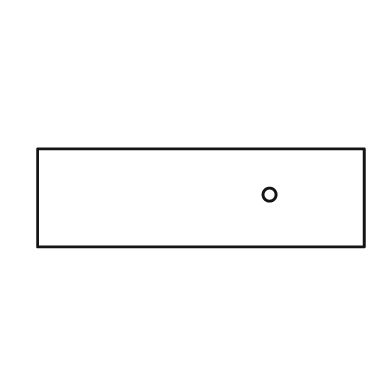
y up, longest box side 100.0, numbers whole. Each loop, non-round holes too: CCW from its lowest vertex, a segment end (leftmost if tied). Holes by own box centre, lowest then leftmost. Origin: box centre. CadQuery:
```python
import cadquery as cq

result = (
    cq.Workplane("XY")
    .moveTo(-50.0, -15.0)
    .lineTo(50.0, -15.0)
    .lineTo(50.0, 15.0)
    .lineTo(-50.0, 15.0)
    .close()
    .moveTo(21.0, 1.0)
    .circle(2.0)
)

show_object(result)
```